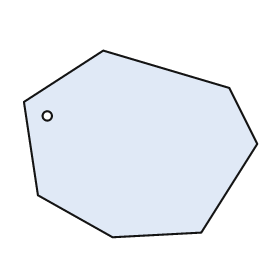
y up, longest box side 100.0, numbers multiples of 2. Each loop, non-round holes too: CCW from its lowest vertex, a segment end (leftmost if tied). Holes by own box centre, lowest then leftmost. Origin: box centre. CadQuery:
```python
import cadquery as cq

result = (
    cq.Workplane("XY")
    .moveTo(-12.0, -40.0)
    .lineTo(26.0, -38.0)
    .lineTo(50.0, 0.0)
    .lineTo(38.0, 24.0)
    .lineTo(-16.0, 40.0)
    .lineTo(-50.0, 18.0)
    .lineTo(-44.0, -22.0)
    .close()
    .moveTo(-40.0, 12.0)
    .circle(2.0)
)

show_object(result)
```